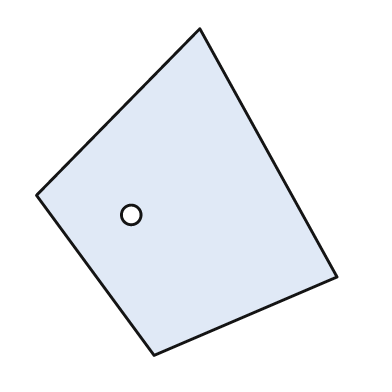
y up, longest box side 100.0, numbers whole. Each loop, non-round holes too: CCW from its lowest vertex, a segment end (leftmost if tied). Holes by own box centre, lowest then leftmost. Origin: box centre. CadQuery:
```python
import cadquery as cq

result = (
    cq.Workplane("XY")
    .moveTo(-10.0, -50.0)
    .lineTo(46.0, -26.0)
    .lineTo(4.0, 50.0)
    .lineTo(-46.0, -1.0)
    .close()
    .moveTo(-17.0, -7.0)
    .circle(3.0)
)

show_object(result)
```